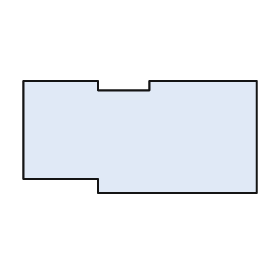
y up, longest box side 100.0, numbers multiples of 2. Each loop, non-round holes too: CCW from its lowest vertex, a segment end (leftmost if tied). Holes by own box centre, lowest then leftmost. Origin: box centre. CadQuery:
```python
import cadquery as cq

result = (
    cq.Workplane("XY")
    .moveTo(-18.0, -24.0)
    .lineTo(50.0, -24.0)
    .lineTo(50.0, 24.0)
    .lineTo(4.0, 24.0)
    .lineTo(4.0, 20.0)
    .lineTo(-18.0, 20.0)
    .lineTo(-18.0, 24.0)
    .lineTo(-50.0, 24.0)
    .lineTo(-50.0, -18.0)
    .lineTo(-18.0, -18.0)
    .close()
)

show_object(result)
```